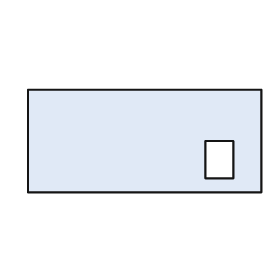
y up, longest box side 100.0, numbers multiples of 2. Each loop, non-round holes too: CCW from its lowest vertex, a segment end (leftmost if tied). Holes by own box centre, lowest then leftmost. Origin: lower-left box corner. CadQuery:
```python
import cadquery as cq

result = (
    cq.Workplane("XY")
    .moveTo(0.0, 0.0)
    .lineTo(100.0, 0.0)
    .lineTo(100.0, 44.0)
    .lineTo(0.0, 44.0)
    .close()
    .moveTo(76.0, 6.0)
    .lineTo(88.0, 6.0)
    .lineTo(88.0, 22.0)
    .lineTo(76.0, 22.0)
    .close()
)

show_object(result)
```